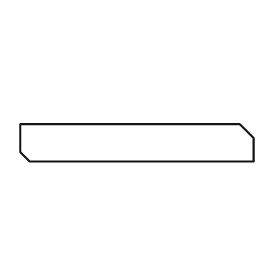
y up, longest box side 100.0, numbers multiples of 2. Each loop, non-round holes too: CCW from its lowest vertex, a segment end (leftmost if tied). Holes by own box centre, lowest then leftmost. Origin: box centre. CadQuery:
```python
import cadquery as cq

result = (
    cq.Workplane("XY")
    .moveTo(-46.0, -8.0)
    .lineTo(50.0, -8.0)
    .lineTo(50.0, 2.0)
    .lineTo(44.0, 8.0)
    .lineTo(-50.0, 8.0)
    .lineTo(-50.0, -4.0)
    .close()
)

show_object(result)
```